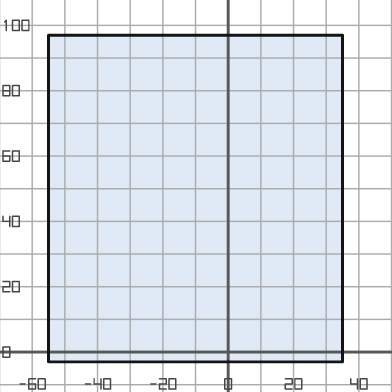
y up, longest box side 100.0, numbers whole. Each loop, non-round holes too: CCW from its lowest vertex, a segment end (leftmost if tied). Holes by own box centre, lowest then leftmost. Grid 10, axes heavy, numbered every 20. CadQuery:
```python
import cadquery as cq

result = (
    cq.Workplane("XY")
    .moveTo(-55.0, -3.0)
    .lineTo(35.0, -3.0)
    .lineTo(35.0, 97.0)
    .lineTo(-55.0, 97.0)
    .close()
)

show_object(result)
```